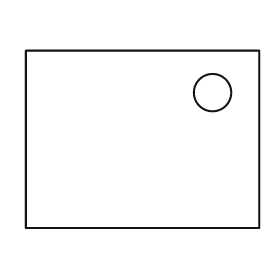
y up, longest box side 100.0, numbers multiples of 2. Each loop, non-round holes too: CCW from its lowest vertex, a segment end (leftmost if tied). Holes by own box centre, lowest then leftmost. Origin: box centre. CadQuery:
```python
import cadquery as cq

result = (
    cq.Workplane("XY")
    .moveTo(-50.0, -38.0)
    .lineTo(50.0, -38.0)
    .lineTo(50.0, 38.0)
    .lineTo(-50.0, 38.0)
    .close()
    .moveTo(30.0, 20.0)
    .circle(8.0)
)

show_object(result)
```